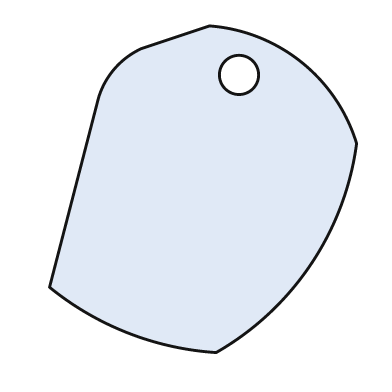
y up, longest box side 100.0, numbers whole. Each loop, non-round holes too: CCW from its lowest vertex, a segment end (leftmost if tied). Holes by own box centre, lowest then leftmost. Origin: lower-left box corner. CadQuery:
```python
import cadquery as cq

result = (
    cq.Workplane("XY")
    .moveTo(51.0, 0.0)
    .threePointArc((80.0, 27.0), (94.0, 64.0))
    .threePointArc((77.0, 89.0), (49.0, 100.0))
    .lineTo(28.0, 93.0)
    .threePointArc((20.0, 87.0), (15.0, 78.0))
    .lineTo(0.0, 20.0)
    .threePointArc((24.0, 6.0), (51.0, 0.0))
    .close()
    .moveTo(58.0, 85.0)
    .circle(6.0)
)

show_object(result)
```